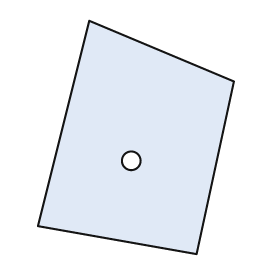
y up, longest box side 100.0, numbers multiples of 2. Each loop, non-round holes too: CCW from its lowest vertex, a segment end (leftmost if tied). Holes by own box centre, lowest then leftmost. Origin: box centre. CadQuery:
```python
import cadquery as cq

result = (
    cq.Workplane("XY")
    .moveTo(26.0, -50.0)
    .lineTo(42.0, 24.0)
    .lineTo(-20.0, 50.0)
    .lineTo(-42.0, -38.0)
    .close()
    .moveTo(-2.0, -10.0)
    .circle(4.0)
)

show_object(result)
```